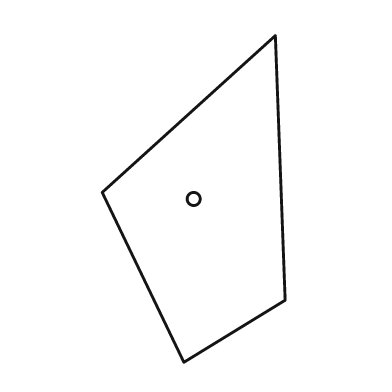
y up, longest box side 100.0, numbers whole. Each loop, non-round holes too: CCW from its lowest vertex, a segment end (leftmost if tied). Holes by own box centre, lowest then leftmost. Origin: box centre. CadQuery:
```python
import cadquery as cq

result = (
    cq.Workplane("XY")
    .moveTo(-3.0, -50.0)
    .lineTo(28.0, -31.0)
    .lineTo(25.0, 50.0)
    .lineTo(-28.0, 2.0)
    .close()
    .moveTo(0.0, 0.0)
    .circle(2.0)
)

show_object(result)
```